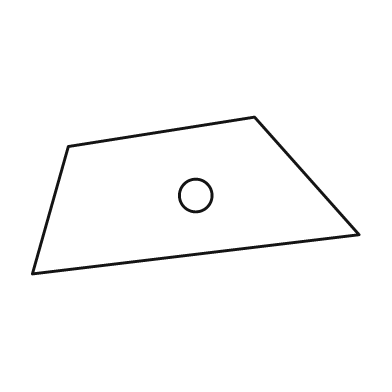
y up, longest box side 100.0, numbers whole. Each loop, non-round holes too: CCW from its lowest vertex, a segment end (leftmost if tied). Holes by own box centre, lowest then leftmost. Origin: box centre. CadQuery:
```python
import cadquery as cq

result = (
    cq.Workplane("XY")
    .moveTo(-50.0, -24.0)
    .lineTo(50.0, -12.0)
    .lineTo(18.0, 24.0)
    .lineTo(-39.0, 15.0)
    .close()
    .moveTo(0.0, 0.0)
    .circle(5.0)
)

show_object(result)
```